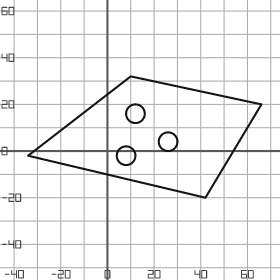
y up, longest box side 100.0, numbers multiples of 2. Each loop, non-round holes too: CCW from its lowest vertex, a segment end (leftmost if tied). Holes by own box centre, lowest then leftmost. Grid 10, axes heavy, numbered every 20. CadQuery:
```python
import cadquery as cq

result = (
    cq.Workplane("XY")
    .moveTo(42.0, -20.0)
    .lineTo(66.0, 20.0)
    .lineTo(10.0, 32.0)
    .lineTo(-34.0, -2.0)
    .close()
    .moveTo(8.0, -2.0)
    .circle(4.0)
    .moveTo(26.0, 4.0)
    .circle(4.0)
    .moveTo(12.0, 16.0)
    .circle(4.0)
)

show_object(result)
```